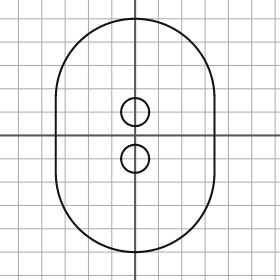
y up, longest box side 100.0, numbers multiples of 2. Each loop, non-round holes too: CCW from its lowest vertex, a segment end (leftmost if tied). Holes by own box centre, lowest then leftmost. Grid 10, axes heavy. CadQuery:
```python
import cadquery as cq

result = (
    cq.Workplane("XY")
    .moveTo(-34.0, -16.0)
    .threePointArc((0.0, -50.0), (34.0, -16.0))
    .lineTo(34.0, 16.0)
    .threePointArc((0.0, 50.0), (-34.0, 16.0))
    .close()
    .moveTo(0.0, -10.0)
    .circle(6.0)
    .moveTo(0.0, 10.0)
    .circle(6.0)
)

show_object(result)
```